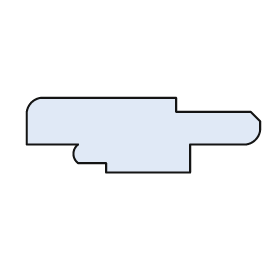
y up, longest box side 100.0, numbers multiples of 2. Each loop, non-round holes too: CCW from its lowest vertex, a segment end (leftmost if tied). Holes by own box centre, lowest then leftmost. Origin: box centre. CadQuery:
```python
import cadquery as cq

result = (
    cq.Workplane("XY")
    .moveTo(-16.0, -16.0)
    .lineTo(20.0, -16.0)
    .lineTo(20.0, -4.0)
    .lineTo(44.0, -4.0)
    .threePointArc((48.0, -2.0), (50.0, 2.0))
    .lineTo(50.0, 6.0)
    .lineTo(46.0, 10.0)
    .lineTo(14.0, 10.0)
    .lineTo(14.0, 16.0)
    .lineTo(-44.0, 16.0)
    .threePointArc((-48.0, 14.0), (-50.0, 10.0))
    .lineTo(-50.0, -4.0)
    .lineTo(-28.0, -4.0)
    .threePointArc((-30.0, -8.0), (-28.0, -12.0))
    .lineTo(-16.0, -12.0)
    .close()
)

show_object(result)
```